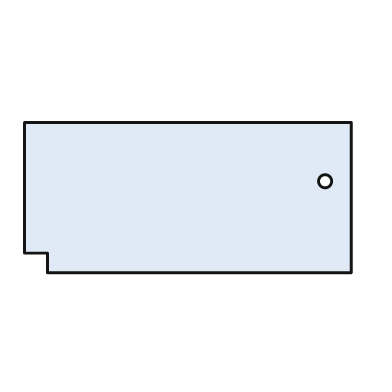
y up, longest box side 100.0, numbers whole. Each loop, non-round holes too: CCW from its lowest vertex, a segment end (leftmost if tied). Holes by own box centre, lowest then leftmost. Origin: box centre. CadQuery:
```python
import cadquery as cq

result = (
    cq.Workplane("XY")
    .moveTo(-43.0, -23.0)
    .lineTo(50.0, -23.0)
    .lineTo(50.0, 23.0)
    .lineTo(-50.0, 23.0)
    .lineTo(-50.0, -17.0)
    .lineTo(-43.0, -17.0)
    .close()
    .moveTo(42.0, 5.0)
    .circle(2.0)
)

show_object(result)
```